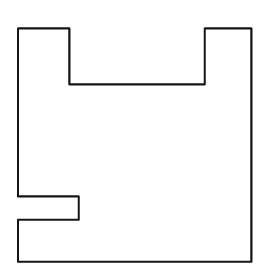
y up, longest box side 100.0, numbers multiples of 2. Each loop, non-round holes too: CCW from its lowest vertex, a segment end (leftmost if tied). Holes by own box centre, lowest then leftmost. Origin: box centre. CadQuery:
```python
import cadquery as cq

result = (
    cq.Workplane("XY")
    .moveTo(-50.0, -50.0)
    .lineTo(50.0, -50.0)
    .lineTo(50.0, 50.0)
    .lineTo(30.0, 50.0)
    .lineTo(30.0, 26.0)
    .lineTo(-28.0, 26.0)
    .lineTo(-28.0, 50.0)
    .lineTo(-50.0, 50.0)
    .lineTo(-50.0, -22.0)
    .lineTo(-24.0, -22.0)
    .lineTo(-24.0, -32.0)
    .lineTo(-50.0, -32.0)
    .close()
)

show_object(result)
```